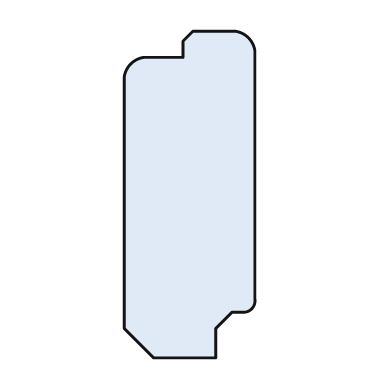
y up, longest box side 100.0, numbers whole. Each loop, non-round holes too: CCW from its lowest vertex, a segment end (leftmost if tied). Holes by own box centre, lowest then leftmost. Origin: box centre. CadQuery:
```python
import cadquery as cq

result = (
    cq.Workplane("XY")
    .moveTo(-11.0, -50.0)
    .lineTo(8.0, -50.0)
    .lineTo(8.0, -41.0)
    .lineTo(13.0, -36.0)
    .lineTo(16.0, -36.0)
    .threePointArc((19.0, -35.0), (20.0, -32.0))
    .lineTo(20.0, 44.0)
    .threePointArc((18.0, 48.0), (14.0, 50.0))
    .lineTo(1.0, 50.0)
    .lineTo(-2.0, 47.0)
    .lineTo(-2.0, 42.0)
    .lineTo(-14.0, 42.0)
    .threePointArc((-18.0, 40.0), (-20.0, 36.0))
    .lineTo(-20.0, -41.0)
    .close()
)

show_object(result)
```